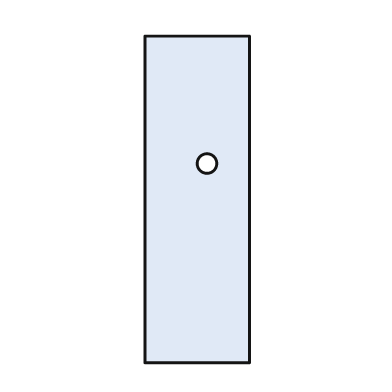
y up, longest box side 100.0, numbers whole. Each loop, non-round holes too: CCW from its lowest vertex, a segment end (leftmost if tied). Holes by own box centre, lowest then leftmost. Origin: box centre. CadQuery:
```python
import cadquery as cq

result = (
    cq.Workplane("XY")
    .moveTo(-16.0, -50.0)
    .lineTo(16.0, -50.0)
    .lineTo(16.0, 50.0)
    .lineTo(-16.0, 50.0)
    .close()
    .moveTo(3.0, 11.0)
    .circle(3.0)
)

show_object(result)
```